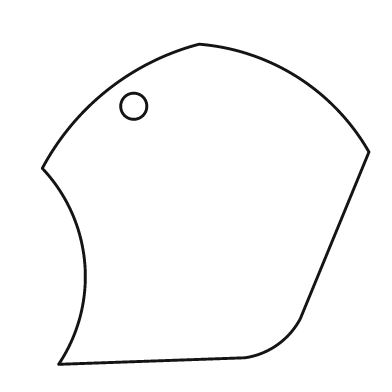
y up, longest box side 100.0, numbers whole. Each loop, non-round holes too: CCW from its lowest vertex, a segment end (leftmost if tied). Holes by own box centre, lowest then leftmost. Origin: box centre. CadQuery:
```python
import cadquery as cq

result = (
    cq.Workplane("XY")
    .moveTo(-45.0, -49.0)
    .lineTo(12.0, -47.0)
    .threePointArc((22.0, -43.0), (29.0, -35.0))
    .lineTo(50.0, 16.0)
    .threePointArc((28.0, 39.0), (-2.0, 49.0))
    .threePointArc((-30.0, 35.0), (-50.0, 11.0))
    .threePointArc((-37.0, -18.0), (-45.0, -49.0))
    .close()
    .moveTo(-22.0, 30.0)
    .circle(4.0)
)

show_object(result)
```